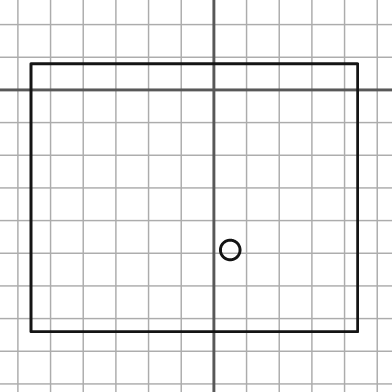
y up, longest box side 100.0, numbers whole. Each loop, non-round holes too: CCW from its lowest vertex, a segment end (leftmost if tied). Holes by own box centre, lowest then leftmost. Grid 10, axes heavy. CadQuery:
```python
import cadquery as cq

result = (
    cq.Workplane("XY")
    .moveTo(-56.0, -74.0)
    .lineTo(44.0, -74.0)
    .lineTo(44.0, 8.0)
    .lineTo(-56.0, 8.0)
    .close()
    .moveTo(5.0, -49.0)
    .circle(3.0)
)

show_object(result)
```